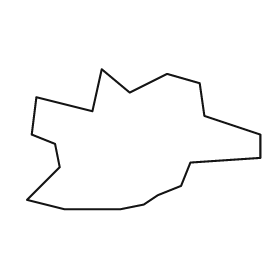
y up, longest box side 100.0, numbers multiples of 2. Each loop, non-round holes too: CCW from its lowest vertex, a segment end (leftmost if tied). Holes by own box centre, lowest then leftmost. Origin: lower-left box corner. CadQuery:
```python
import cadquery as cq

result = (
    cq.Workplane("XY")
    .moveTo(16.0, 0.0)
    .lineTo(40.0, 0.0)
    .lineTo(50.0, 2.0)
    .lineTo(56.0, 6.0)
    .lineTo(66.0, 10.0)
    .lineTo(70.0, 20.0)
    .lineTo(100.0, 22.0)
    .lineTo(100.0, 32.0)
    .lineTo(76.0, 40.0)
    .lineTo(74.0, 54.0)
    .lineTo(60.0, 58.0)
    .lineTo(44.0, 50.0)
    .lineTo(32.0, 60.0)
    .lineTo(28.0, 42.0)
    .lineTo(4.0, 48.0)
    .lineTo(2.0, 32.0)
    .lineTo(12.0, 28.0)
    .lineTo(14.0, 18.0)
    .lineTo(0.0, 4.0)
    .close()
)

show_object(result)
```